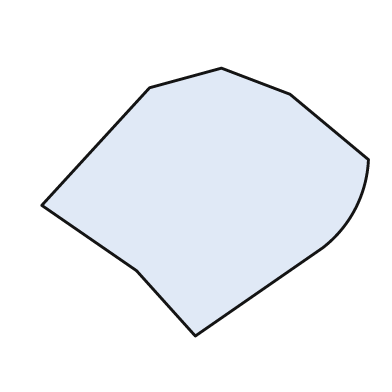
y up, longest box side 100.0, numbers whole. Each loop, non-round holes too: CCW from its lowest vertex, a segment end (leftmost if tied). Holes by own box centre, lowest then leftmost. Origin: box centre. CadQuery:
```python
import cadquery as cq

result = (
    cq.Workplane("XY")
    .moveTo(-3.0, -41.0)
    .lineTo(36.0, -14.0)
    .threePointArc((46.0, -2.0), (50.0, 13.0))
    .lineTo(26.0, 33.0)
    .lineTo(5.0, 41.0)
    .lineTo(-17.0, 35.0)
    .lineTo(-50.0, -1.0)
    .lineTo(-21.0, -21.0)
    .close()
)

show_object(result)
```